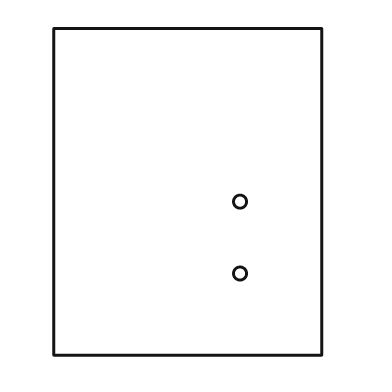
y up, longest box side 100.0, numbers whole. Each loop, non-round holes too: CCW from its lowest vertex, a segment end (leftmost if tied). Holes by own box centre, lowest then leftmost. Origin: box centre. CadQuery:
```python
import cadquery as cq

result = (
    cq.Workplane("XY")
    .moveTo(-41.0, -50.0)
    .lineTo(41.0, -50.0)
    .lineTo(41.0, 50.0)
    .lineTo(-41.0, 50.0)
    .close()
    .moveTo(16.0, -25.0)
    .circle(2.0)
    .moveTo(16.0, -3.0)
    .circle(2.0)
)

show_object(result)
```